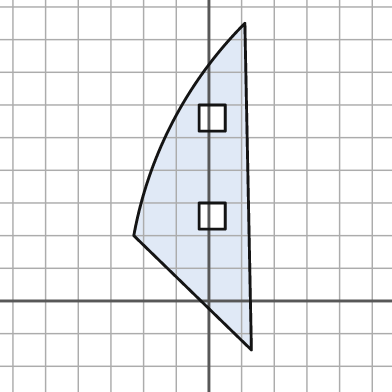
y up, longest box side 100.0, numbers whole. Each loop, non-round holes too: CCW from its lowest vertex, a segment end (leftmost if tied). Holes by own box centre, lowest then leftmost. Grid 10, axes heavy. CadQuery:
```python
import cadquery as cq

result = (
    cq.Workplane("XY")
    .moveTo(13.0, -15.0)
    .lineTo(11.0, 85.0)
    .threePointArc((-11.0, 55.0), (-23.0, 20.0))
    .close()
    .moveTo(-3.0, 22.0)
    .lineTo(5.0, 22.0)
    .lineTo(5.0, 30.0)
    .lineTo(-3.0, 30.0)
    .close()
    .moveTo(-3.0, 52.0)
    .lineTo(5.0, 52.0)
    .lineTo(5.0, 60.0)
    .lineTo(-3.0, 60.0)
    .close()
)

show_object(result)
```